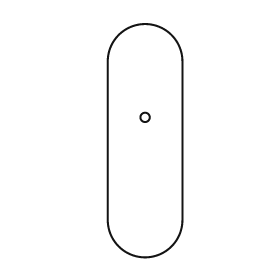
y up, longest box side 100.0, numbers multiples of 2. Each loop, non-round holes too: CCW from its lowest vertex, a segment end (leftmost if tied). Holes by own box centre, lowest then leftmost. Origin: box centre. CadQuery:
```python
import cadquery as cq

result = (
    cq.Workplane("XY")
    .moveTo(-16.0, -34.0)
    .threePointArc((0.0, -50.0), (16.0, -34.0))
    .lineTo(16.0, 34.0)
    .threePointArc((0.0, 50.0), (-16.0, 34.0))
    .close()
    .moveTo(0.0, 10.0)
    .circle(2.0)
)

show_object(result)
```